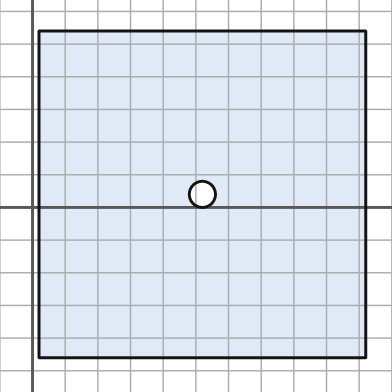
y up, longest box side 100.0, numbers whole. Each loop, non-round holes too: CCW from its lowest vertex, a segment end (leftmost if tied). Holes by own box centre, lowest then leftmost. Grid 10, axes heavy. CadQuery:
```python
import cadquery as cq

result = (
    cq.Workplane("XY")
    .moveTo(2.0, -46.0)
    .lineTo(102.0, -46.0)
    .lineTo(102.0, 54.0)
    .lineTo(2.0, 54.0)
    .close()
    .moveTo(52.0, 4.0)
    .circle(4.0)
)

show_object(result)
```